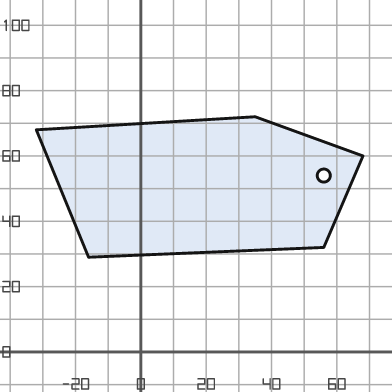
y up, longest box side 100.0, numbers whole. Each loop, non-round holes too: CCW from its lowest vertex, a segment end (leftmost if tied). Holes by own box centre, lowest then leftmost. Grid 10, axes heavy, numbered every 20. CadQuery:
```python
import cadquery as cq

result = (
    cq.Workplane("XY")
    .moveTo(-16.0, 29.0)
    .lineTo(56.0, 32.0)
    .lineTo(68.0, 60.0)
    .lineTo(35.0, 72.0)
    .lineTo(-32.0, 68.0)
    .close()
    .moveTo(56.0, 54.0)
    .circle(2.0)
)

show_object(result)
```